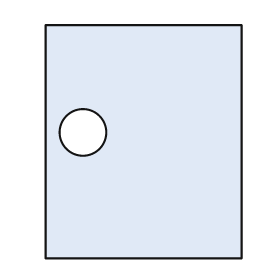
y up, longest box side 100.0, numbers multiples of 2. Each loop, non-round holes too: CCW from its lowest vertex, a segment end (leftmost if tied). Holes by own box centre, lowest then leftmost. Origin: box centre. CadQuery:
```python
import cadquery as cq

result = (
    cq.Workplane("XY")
    .moveTo(-42.0, -50.0)
    .lineTo(42.0, -50.0)
    .lineTo(42.0, 50.0)
    .lineTo(-42.0, 50.0)
    .close()
    .moveTo(-26.0, 4.0)
    .circle(10.0)
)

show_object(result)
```